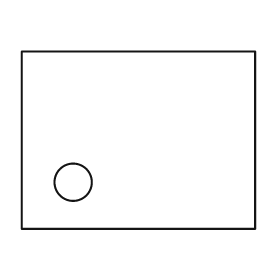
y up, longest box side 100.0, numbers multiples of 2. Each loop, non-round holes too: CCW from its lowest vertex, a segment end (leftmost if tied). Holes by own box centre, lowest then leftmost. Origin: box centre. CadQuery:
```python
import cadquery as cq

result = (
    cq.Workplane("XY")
    .moveTo(-50.0, -38.0)
    .lineTo(50.0, -38.0)
    .lineTo(50.0, 38.0)
    .lineTo(-50.0, 38.0)
    .close()
    .moveTo(-28.0, -18.0)
    .circle(8.0)
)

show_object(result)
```